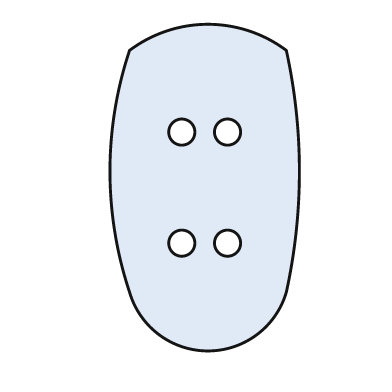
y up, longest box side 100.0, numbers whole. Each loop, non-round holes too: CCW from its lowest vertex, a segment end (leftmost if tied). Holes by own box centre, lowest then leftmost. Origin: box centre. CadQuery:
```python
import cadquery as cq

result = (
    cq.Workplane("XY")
    .moveTo(-23.0, -32.0)
    .threePointArc((1.0, -50.0), (25.0, -32.0))
    .threePointArc((29.0, 5.0), (25.0, 42.0))
    .threePointArc((1.0, 50.0), (-23.0, 42.0))
    .threePointArc((-29.0, 5.0), (-23.0, -32.0))
    .close()
    .moveTo(-7.0, -17.0)
    .circle(4.0)
    .moveTo(7.0, -17.0)
    .circle(4.0)
    .moveTo(-7.0, 17.0)
    .circle(4.0)
    .moveTo(7.0, 17.0)
    .circle(4.0)
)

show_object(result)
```